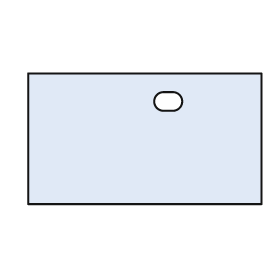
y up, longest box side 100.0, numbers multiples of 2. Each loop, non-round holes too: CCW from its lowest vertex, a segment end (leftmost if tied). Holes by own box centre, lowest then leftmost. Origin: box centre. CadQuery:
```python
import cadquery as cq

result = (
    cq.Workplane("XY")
    .moveTo(-50.0, -28.0)
    .lineTo(50.0, -28.0)
    .lineTo(50.0, 28.0)
    .lineTo(-50.0, 28.0)
    .close()
    .moveTo(8.0, 12.0)
    .lineTo(12.0, 12.0)
    .threePointArc((16.0, 16.0), (12.0, 20.0))
    .lineTo(8.0, 20.0)
    .threePointArc((4.0, 16.0), (8.0, 12.0))
    .close()
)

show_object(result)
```